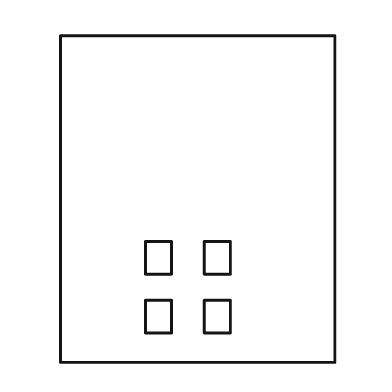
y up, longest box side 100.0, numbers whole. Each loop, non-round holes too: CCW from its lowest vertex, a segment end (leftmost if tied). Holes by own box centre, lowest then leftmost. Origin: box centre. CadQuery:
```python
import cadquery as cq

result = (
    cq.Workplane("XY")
    .moveTo(-42.0, -50.0)
    .lineTo(42.0, -50.0)
    .lineTo(42.0, 50.0)
    .lineTo(-42.0, 50.0)
    .close()
    .moveTo(-16.0, -41.0)
    .lineTo(-8.0, -41.0)
    .lineTo(-8.0, -31.0)
    .lineTo(-16.0, -31.0)
    .close()
    .moveTo(2.0, -41.0)
    .lineTo(10.0, -41.0)
    .lineTo(10.0, -31.0)
    .lineTo(2.0, -31.0)
    .close()
    .moveTo(-16.0, -23.0)
    .lineTo(-8.0, -23.0)
    .lineTo(-8.0, -13.0)
    .lineTo(-16.0, -13.0)
    .close()
    .moveTo(2.0, -23.0)
    .lineTo(10.0, -23.0)
    .lineTo(10.0, -13.0)
    .lineTo(2.0, -13.0)
    .close()
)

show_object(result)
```